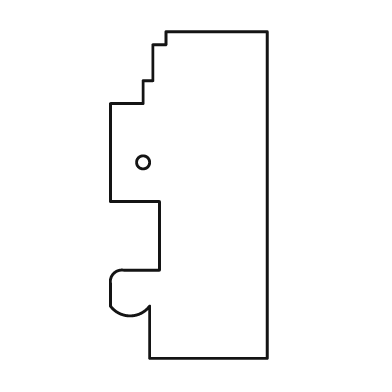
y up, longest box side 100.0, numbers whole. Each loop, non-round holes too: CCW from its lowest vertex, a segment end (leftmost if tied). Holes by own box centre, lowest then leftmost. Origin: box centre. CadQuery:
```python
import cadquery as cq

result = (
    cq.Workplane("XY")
    .moveTo(-12.0, -50.0)
    .lineTo(24.0, -50.0)
    .lineTo(24.0, 50.0)
    .lineTo(-7.0, 50.0)
    .lineTo(-7.0, 46.0)
    .lineTo(-11.0, 46.0)
    .lineTo(-11.0, 35.0)
    .lineTo(-14.0, 35.0)
    .lineTo(-14.0, 28.0)
    .lineTo(-24.0, 28.0)
    .lineTo(-24.0, -2.0)
    .lineTo(-9.0, -2.0)
    .lineTo(-9.0, -23.0)
    .lineTo(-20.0, -23.0)
    .threePointArc((-23.0, -24.0), (-24.0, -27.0))
    .lineTo(-24.0, -34.0)
    .threePointArc((-18.0, -37.0), (-12.0, -34.0))
    .close()
    .moveTo(-14.0, 10.0)
    .circle(2.0)
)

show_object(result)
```